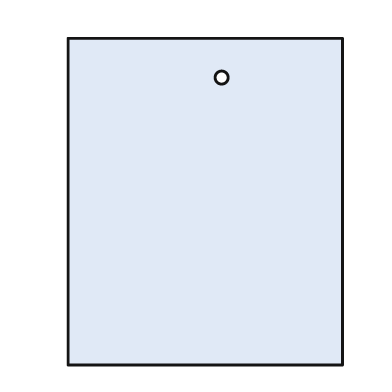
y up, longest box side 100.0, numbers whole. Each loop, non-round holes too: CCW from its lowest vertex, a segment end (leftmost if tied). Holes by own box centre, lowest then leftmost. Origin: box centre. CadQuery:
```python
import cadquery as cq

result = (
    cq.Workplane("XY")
    .moveTo(-42.0, -50.0)
    .lineTo(42.0, -50.0)
    .lineTo(42.0, 50.0)
    .lineTo(-42.0, 50.0)
    .close()
    .moveTo(5.0, 38.0)
    .circle(2.0)
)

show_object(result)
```